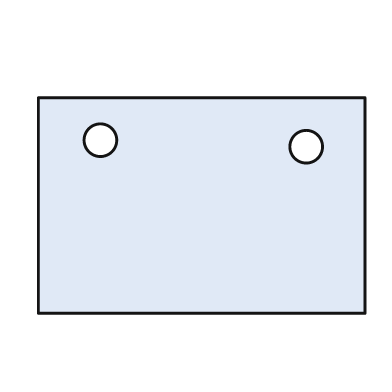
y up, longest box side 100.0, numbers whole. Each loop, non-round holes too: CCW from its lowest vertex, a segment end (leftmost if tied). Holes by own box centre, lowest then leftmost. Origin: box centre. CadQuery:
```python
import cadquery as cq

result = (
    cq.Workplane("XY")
    .moveTo(-50.0, -33.0)
    .lineTo(50.0, -33.0)
    .lineTo(50.0, 33.0)
    .lineTo(-50.0, 33.0)
    .close()
    .moveTo(32.0, 18.0)
    .circle(5.0)
    .moveTo(-31.0, 20.0)
    .circle(5.0)
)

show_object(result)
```